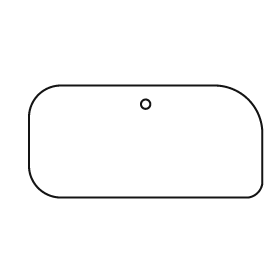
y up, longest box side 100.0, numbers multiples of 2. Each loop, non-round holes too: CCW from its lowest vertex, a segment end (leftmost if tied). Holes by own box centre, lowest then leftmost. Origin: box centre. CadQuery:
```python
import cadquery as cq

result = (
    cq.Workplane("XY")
    .moveTo(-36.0, -24.0)
    .lineTo(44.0, -24.0)
    .threePointArc((48.0, -22.0), (50.0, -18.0))
    .lineTo(50.0, 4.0)
    .threePointArc((44.0, 18.0), (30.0, 24.0))
    .lineTo(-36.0, 24.0)
    .threePointArc((-46.0, 20.0), (-50.0, 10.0))
    .lineTo(-50.0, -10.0)
    .threePointArc((-46.0, -20.0), (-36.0, -24.0))
    .close()
    .moveTo(0.0, 16.0)
    .circle(2.0)
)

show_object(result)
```